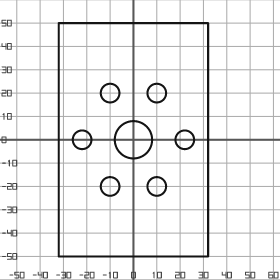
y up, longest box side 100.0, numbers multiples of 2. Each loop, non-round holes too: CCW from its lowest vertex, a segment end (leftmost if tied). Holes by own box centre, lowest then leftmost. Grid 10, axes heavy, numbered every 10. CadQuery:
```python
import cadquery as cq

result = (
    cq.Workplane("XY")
    .moveTo(-32.0, -50.0)
    .lineTo(32.0, -50.0)
    .lineTo(32.0, 50.0)
    .lineTo(-32.0, 50.0)
    .close()
    .moveTo(-10.0, -20.0)
    .circle(4.0)
    .moveTo(10.0, -20.0)
    .circle(4.0)
    .moveTo(-22.0, 0.0)
    .circle(4.0)
    .moveTo(0.0, 0.0)
    .circle(8.0)
    .moveTo(22.0, 0.0)
    .circle(4.0)
    .moveTo(-10.0, 20.0)
    .circle(4.0)
    .moveTo(10.0, 20.0)
    .circle(4.0)
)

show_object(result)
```